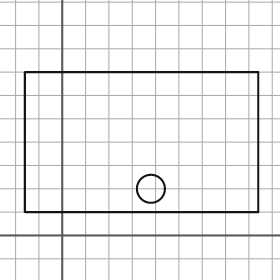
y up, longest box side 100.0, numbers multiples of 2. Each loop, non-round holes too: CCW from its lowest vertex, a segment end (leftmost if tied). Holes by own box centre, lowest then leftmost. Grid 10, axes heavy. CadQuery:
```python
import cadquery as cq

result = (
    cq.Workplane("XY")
    .moveTo(-16.0, 10.0)
    .lineTo(84.0, 10.0)
    .lineTo(84.0, 70.0)
    .lineTo(-16.0, 70.0)
    .close()
    .moveTo(38.0, 20.0)
    .circle(6.0)
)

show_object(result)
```